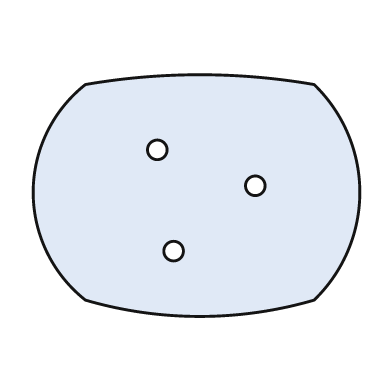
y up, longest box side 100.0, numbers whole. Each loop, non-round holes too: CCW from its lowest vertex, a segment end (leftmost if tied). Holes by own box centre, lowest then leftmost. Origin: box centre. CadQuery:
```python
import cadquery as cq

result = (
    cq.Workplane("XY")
    .moveTo(-34.0, -32.0)
    .threePointArc((1.0, -37.0), (36.0, -32.0))
    .threePointArc((50.0, 1.0), (36.0, 34.0))
    .threePointArc((1.0, 37.0), (-34.0, 34.0))
    .threePointArc((-50.0, 1.0), (-34.0, -32.0))
    .close()
    .moveTo(-7.0, -17.0)
    .circle(3.0)
    .moveTo(18.0, 3.0)
    .circle(3.0)
    .moveTo(-12.0, 14.0)
    .circle(3.0)
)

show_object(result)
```